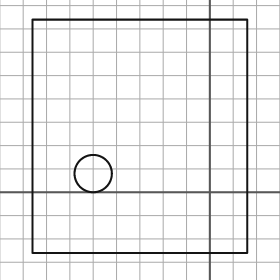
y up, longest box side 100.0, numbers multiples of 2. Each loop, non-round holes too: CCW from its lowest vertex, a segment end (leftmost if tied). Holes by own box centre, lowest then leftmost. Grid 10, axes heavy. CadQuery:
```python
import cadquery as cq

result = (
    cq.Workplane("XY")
    .moveTo(-76.0, -26.0)
    .lineTo(16.0, -26.0)
    .lineTo(16.0, 74.0)
    .lineTo(-76.0, 74.0)
    .close()
    .moveTo(-50.0, 8.0)
    .circle(8.0)
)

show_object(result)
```